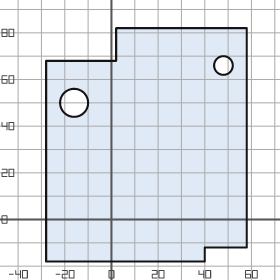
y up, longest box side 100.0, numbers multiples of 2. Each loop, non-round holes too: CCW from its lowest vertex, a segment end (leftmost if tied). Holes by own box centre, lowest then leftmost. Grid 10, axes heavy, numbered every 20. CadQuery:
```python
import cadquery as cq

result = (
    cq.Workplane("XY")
    .moveTo(-28.0, -18.0)
    .lineTo(40.0, -18.0)
    .lineTo(40.0, -12.0)
    .lineTo(58.0, -12.0)
    .lineTo(58.0, 82.0)
    .lineTo(2.0, 82.0)
    .lineTo(2.0, 68.0)
    .lineTo(-28.0, 68.0)
    .close()
    .moveTo(-16.0, 50.0)
    .circle(6.0)
    .moveTo(48.0, 66.0)
    .circle(4.0)
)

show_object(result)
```